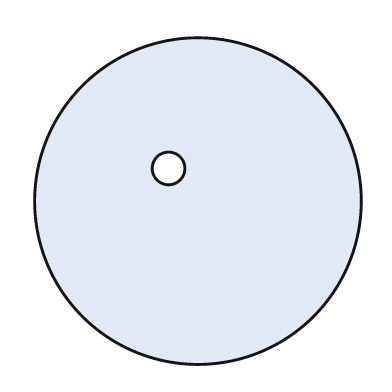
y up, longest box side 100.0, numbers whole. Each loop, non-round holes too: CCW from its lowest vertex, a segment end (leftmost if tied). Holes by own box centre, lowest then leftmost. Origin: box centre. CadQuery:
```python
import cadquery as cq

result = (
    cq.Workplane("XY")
    .moveTo(0.0, 0.0)
    .circle(50.0)
    .moveTo(-9.0, 10.0)
    .circle(5.0)
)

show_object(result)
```